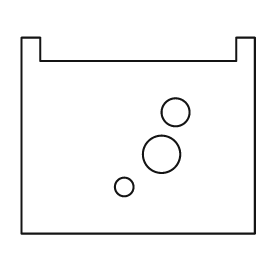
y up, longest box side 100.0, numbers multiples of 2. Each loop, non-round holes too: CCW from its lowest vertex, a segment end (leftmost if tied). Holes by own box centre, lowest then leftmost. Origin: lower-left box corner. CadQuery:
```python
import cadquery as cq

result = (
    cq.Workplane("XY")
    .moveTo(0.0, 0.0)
    .lineTo(100.0, 0.0)
    .lineTo(100.0, 84.0)
    .lineTo(92.0, 84.0)
    .lineTo(92.0, 74.0)
    .lineTo(8.0, 74.0)
    .lineTo(8.0, 84.0)
    .lineTo(0.0, 84.0)
    .close()
    .moveTo(44.0, 20.0)
    .circle(4.0)
    .moveTo(60.0, 34.0)
    .circle(8.0)
    .moveTo(66.0, 52.0)
    .circle(6.0)
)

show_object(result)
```